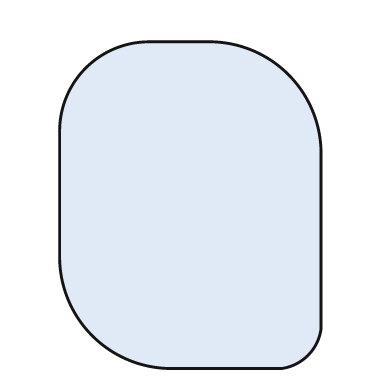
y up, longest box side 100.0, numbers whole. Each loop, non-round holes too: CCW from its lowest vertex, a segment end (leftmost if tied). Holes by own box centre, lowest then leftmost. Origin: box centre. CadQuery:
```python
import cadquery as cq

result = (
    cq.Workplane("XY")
    .moveTo(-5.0, -50.0)
    .lineTo(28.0, -50.0)
    .threePointArc((36.0, -46.0), (40.0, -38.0))
    .lineTo(40.0, 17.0)
    .threePointArc((30.0, 40.0), (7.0, 50.0))
    .lineTo(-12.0, 50.0)
    .threePointArc((-32.0, 42.0), (-40.0, 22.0))
    .lineTo(-40.0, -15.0)
    .threePointArc((-30.0, -40.0), (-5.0, -50.0))
    .close()
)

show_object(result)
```